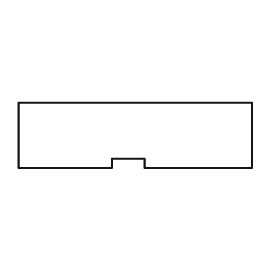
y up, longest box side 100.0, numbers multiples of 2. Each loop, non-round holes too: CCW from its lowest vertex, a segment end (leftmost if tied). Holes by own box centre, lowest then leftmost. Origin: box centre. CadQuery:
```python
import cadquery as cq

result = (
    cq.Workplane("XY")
    .moveTo(-50.0, -14.0)
    .lineTo(-10.0, -14.0)
    .lineTo(-10.0, -10.0)
    .lineTo(4.0, -10.0)
    .lineTo(4.0, -14.0)
    .lineTo(50.0, -14.0)
    .lineTo(50.0, 14.0)
    .lineTo(-50.0, 14.0)
    .close()
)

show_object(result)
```